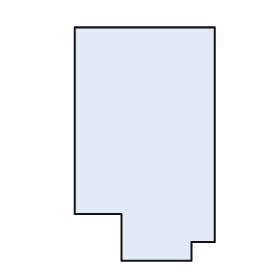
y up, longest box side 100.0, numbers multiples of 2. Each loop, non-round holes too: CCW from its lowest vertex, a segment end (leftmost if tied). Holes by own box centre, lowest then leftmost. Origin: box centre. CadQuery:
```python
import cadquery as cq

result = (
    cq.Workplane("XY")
    .moveTo(-10.0, -50.0)
    .lineTo(20.0, -50.0)
    .lineTo(20.0, -42.0)
    .lineTo(30.0, -42.0)
    .lineTo(30.0, 50.0)
    .lineTo(-30.0, 50.0)
    .lineTo(-30.0, -30.0)
    .lineTo(-10.0, -30.0)
    .close()
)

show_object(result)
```